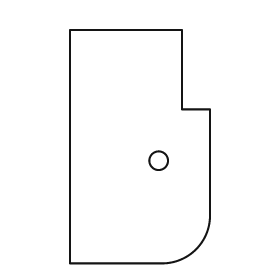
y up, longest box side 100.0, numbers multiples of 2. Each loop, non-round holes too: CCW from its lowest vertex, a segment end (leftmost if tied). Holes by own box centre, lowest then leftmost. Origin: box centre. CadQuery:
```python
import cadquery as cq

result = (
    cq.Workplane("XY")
    .moveTo(-30.0, -50.0)
    .lineTo(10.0, -50.0)
    .threePointArc((24.0, -44.0), (30.0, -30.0))
    .lineTo(30.0, 16.0)
    .lineTo(18.0, 16.0)
    .lineTo(18.0, 50.0)
    .lineTo(-30.0, 50.0)
    .close()
    .moveTo(8.0, -6.0)
    .circle(4.0)
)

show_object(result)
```